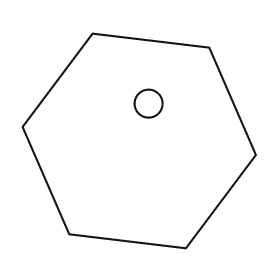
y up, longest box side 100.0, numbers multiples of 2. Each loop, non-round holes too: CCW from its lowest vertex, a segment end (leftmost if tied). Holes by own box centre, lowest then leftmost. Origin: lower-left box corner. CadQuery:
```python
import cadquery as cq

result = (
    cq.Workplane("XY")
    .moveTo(70.0, 0.0)
    .lineTo(100.0, 40.0)
    .lineTo(80.0, 86.0)
    .lineTo(30.0, 92.0)
    .lineTo(0.0, 52.0)
    .lineTo(20.0, 6.0)
    .close()
    .moveTo(54.0, 62.0)
    .circle(6.0)
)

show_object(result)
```